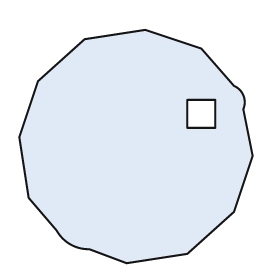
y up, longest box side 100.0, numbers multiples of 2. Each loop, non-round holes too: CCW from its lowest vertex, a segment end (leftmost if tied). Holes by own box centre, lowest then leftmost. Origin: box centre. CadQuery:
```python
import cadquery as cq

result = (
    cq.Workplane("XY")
    .moveTo(-4.0, -50.0)
    .lineTo(22.0, -46.0)
    .lineTo(42.0, -28.0)
    .lineTo(50.0, -4.0)
    .lineTo(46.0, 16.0)
    .threePointArc((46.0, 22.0), (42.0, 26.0))
    .lineTo(28.0, 42.0)
    .lineTo(4.0, 50.0)
    .lineTo(-22.0, 46.0)
    .lineTo(-42.0, 28.0)
    .lineTo(-50.0, 4.0)
    .lineTo(-46.0, -22.0)
    .lineTo(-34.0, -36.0)
    .threePointArc((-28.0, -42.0), (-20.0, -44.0))
    .close()
    .moveTo(22.0, 8.0)
    .lineTo(34.0, 8.0)
    .lineTo(34.0, 20.0)
    .lineTo(22.0, 20.0)
    .close()
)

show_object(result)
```